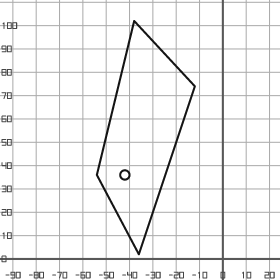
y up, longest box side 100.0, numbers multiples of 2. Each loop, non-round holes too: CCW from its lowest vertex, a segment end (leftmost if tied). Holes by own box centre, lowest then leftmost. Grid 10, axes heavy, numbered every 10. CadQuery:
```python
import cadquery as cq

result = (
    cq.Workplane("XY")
    .moveTo(-36.0, 2.0)
    .lineTo(-12.0, 74.0)
    .lineTo(-38.0, 102.0)
    .lineTo(-54.0, 36.0)
    .close()
    .moveTo(-42.0, 36.0)
    .circle(2.0)
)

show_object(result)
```